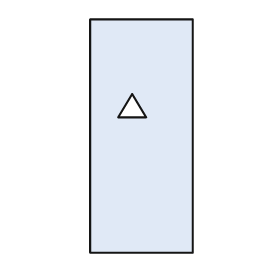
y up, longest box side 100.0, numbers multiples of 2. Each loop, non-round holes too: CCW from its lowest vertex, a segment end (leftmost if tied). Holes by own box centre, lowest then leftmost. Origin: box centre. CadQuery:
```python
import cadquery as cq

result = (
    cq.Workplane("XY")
    .moveTo(-22.0, -50.0)
    .lineTo(22.0, -50.0)
    .lineTo(22.0, 50.0)
    .lineTo(-22.0, 50.0)
    .close()
    .moveTo(-10.0, 8.0)
    .lineTo(2.0, 8.0)
    .lineTo(-4.0, 18.0)
    .close()
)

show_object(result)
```